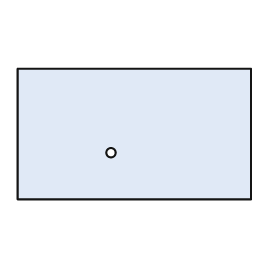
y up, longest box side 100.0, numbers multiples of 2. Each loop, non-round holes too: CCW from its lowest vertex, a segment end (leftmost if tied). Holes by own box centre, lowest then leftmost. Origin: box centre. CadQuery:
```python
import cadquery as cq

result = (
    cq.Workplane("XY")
    .moveTo(-50.0, -28.0)
    .lineTo(50.0, -28.0)
    .lineTo(50.0, 28.0)
    .lineTo(-50.0, 28.0)
    .close()
    .moveTo(-10.0, -8.0)
    .circle(2.0)
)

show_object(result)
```